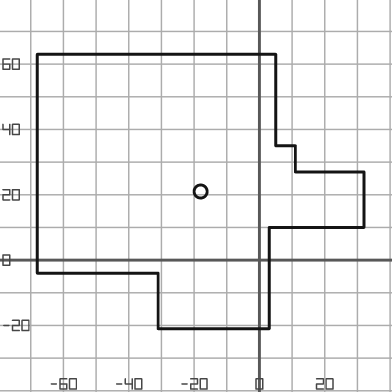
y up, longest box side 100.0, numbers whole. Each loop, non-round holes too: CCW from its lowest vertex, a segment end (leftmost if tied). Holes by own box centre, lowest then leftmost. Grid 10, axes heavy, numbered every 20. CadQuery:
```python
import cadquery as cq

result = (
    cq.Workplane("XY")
    .moveTo(-31.0, -21.0)
    .lineTo(3.0, -21.0)
    .lineTo(3.0, 10.0)
    .lineTo(32.0, 10.0)
    .lineTo(32.0, 27.0)
    .lineTo(11.0, 27.0)
    .lineTo(11.0, 35.0)
    .lineTo(5.0, 35.0)
    .lineTo(5.0, 63.0)
    .lineTo(-68.0, 63.0)
    .lineTo(-68.0, -4.0)
    .lineTo(-31.0, -4.0)
    .close()
    .moveTo(-18.0, 21.0)
    .circle(2.0)
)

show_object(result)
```